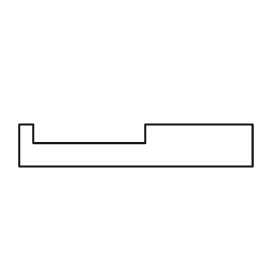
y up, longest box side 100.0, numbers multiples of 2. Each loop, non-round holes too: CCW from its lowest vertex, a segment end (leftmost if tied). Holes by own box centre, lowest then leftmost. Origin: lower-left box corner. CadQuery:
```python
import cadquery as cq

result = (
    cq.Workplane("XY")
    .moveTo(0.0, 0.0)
    .lineTo(100.0, 0.0)
    .lineTo(100.0, 18.0)
    .lineTo(54.0, 18.0)
    .lineTo(54.0, 10.0)
    .lineTo(6.0, 10.0)
    .lineTo(6.0, 18.0)
    .lineTo(0.0, 18.0)
    .close()
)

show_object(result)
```